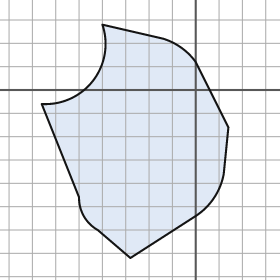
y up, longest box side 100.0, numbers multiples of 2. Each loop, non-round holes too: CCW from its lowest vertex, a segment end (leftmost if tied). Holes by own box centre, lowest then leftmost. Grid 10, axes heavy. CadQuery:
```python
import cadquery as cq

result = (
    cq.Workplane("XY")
    .moveTo(-28.0, -72.0)
    .lineTo(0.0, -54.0)
    .threePointArc((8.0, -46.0), (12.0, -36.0))
    .lineTo(14.0, -16.0)
    .lineTo(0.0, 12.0)
    .threePointArc((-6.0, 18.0), (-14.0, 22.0))
    .lineTo(-40.0, 28.0)
    .threePointArc((-44.0, 4.0), (-66.0, -6.0))
    .lineTo(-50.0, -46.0)
    .threePointArc((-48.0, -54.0), (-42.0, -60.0))
    .close()
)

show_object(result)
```